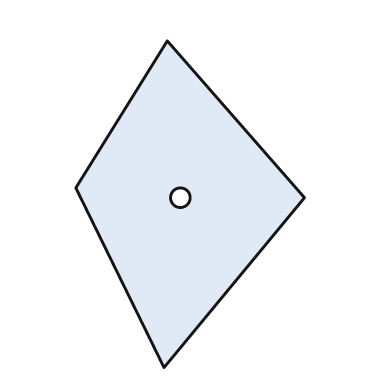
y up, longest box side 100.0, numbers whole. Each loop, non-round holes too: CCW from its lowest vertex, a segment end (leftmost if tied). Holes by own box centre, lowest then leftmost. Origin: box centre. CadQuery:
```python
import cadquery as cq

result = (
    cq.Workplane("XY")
    .moveTo(-8.0, -50.0)
    .lineTo(35.0, 2.0)
    .lineTo(-7.0, 50.0)
    .lineTo(-35.0, 5.0)
    .close()
    .moveTo(-3.0, 2.0)
    .circle(3.0)
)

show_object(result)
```